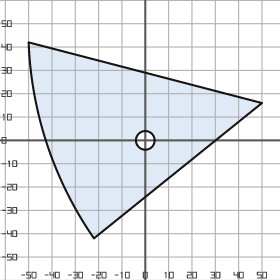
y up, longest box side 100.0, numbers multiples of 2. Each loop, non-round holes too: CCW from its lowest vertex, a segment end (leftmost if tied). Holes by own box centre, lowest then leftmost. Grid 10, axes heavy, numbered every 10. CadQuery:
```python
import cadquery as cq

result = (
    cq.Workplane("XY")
    .moveTo(-22.0, -42.0)
    .lineTo(50.0, 16.0)
    .lineTo(-50.0, 42.0)
    .threePointArc((-42.0, -2.0), (-22.0, -42.0))
    .close()
    .moveTo(0.0, 0.0)
    .circle(4.0)
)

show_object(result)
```